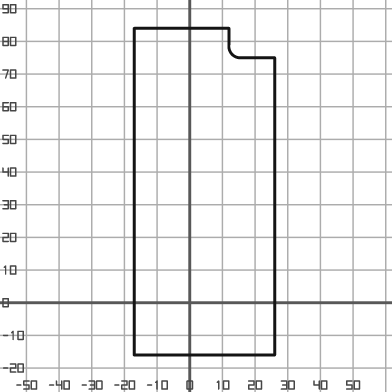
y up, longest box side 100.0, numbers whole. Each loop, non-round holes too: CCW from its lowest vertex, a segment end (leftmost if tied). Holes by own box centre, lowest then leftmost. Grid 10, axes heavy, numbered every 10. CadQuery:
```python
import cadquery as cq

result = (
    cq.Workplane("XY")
    .moveTo(-17.0, -16.0)
    .lineTo(26.0, -16.0)
    .lineTo(26.0, 75.0)
    .lineTo(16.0, 75.0)
    .threePointArc((13.0, 76.0), (12.0, 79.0))
    .lineTo(12.0, 84.0)
    .lineTo(-17.0, 84.0)
    .close()
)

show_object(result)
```